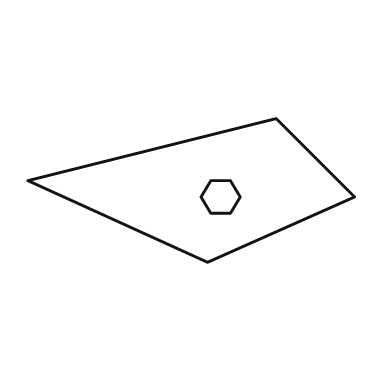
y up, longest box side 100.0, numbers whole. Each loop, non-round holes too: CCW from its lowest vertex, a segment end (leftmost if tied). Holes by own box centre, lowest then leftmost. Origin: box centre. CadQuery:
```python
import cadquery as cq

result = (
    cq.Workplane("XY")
    .moveTo(5.0, -22.0)
    .lineTo(50.0, -2.0)
    .lineTo(26.0, 22.0)
    .lineTo(-50.0, 3.0)
    .close()
    .moveTo(6.0, -7.0)
    .lineTo(12.0, -7.0)
    .lineTo(15.0, -2.0)
    .lineTo(12.0, 3.0)
    .lineTo(6.0, 3.0)
    .lineTo(3.0, -2.0)
    .close()
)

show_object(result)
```